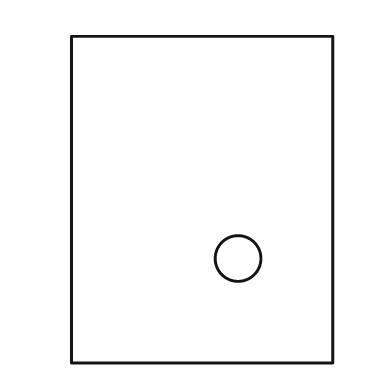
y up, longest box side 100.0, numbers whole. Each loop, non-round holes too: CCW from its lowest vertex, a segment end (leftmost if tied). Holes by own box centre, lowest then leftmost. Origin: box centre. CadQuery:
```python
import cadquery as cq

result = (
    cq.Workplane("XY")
    .moveTo(-40.0, -50.0)
    .lineTo(40.0, -50.0)
    .lineTo(40.0, 50.0)
    .lineTo(-40.0, 50.0)
    .close()
    .moveTo(11.0, -18.0)
    .circle(7.0)
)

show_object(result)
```